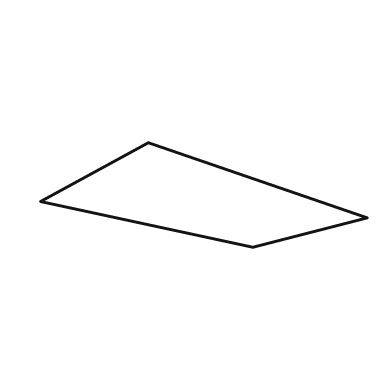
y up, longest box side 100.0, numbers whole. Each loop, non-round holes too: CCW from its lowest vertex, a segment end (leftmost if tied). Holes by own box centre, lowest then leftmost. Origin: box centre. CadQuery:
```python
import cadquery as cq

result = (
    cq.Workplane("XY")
    .moveTo(15.0, -16.0)
    .lineTo(50.0, -7.0)
    .lineTo(-17.0, 16.0)
    .lineTo(-50.0, -2.0)
    .close()
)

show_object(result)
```